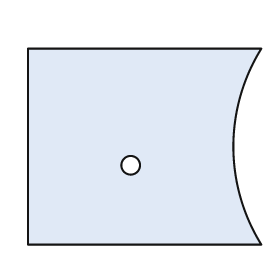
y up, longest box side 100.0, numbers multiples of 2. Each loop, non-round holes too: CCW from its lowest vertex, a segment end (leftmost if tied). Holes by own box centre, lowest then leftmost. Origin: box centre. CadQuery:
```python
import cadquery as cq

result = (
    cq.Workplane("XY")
    .moveTo(-50.0, -42.0)
    .lineTo(50.0, -42.0)
    .threePointArc((38.0, 0.0), (50.0, 42.0))
    .lineTo(-50.0, 42.0)
    .close()
    .moveTo(-6.0, -8.0)
    .circle(4.0)
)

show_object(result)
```